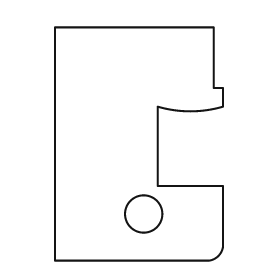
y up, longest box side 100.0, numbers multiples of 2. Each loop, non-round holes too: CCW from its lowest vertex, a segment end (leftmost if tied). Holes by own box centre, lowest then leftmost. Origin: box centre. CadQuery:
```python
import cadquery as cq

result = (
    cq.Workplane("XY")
    .moveTo(-36.0, -50.0)
    .lineTo(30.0, -50.0)
    .threePointArc((34.0, -48.0), (36.0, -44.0))
    .lineTo(36.0, -18.0)
    .lineTo(8.0, -18.0)
    .lineTo(8.0, 16.0)
    .threePointArc((22.0, 14.0), (36.0, 16.0))
    .lineTo(36.0, 24.0)
    .lineTo(32.0, 24.0)
    .lineTo(32.0, 50.0)
    .lineTo(-36.0, 50.0)
    .close()
    .moveTo(2.0, -30.0)
    .circle(8.0)
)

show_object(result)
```